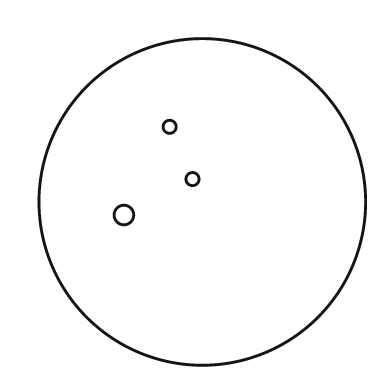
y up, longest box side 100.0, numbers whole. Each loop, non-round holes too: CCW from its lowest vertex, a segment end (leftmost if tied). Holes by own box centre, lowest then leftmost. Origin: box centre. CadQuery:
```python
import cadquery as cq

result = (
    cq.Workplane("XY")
    .moveTo(0.0, 0.0)
    .circle(50.0)
    .moveTo(-24.0, -4.0)
    .circle(3.0)
    .moveTo(-3.0, 7.0)
    .circle(2.0)
    .moveTo(-10.0, 23.0)
    .circle(2.0)
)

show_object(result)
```